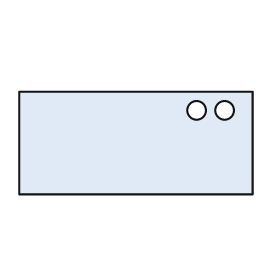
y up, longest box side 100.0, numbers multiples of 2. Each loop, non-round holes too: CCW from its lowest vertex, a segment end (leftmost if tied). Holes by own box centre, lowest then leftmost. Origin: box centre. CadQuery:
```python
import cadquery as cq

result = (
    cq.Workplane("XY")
    .moveTo(-50.0, -22.0)
    .lineTo(50.0, -22.0)
    .lineTo(50.0, 22.0)
    .lineTo(-50.0, 22.0)
    .close()
    .moveTo(26.0, 14.0)
    .circle(4.0)
    .moveTo(38.0, 14.0)
    .circle(4.0)
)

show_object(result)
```